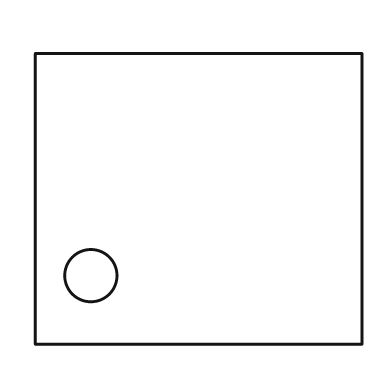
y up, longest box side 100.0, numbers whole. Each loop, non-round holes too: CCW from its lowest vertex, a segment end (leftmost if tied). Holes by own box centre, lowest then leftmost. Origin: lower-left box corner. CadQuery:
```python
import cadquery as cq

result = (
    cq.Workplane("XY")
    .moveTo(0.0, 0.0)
    .lineTo(100.0, 0.0)
    .lineTo(100.0, 89.0)
    .lineTo(0.0, 89.0)
    .close()
    .moveTo(17.0, 21.0)
    .circle(8.0)
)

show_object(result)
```